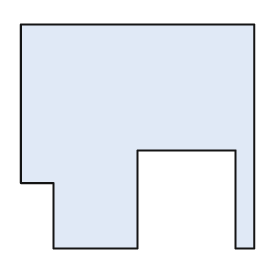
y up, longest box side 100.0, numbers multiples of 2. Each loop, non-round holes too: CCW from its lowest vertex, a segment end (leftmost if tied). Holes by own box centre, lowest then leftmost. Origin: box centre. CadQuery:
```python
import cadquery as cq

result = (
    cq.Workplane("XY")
    .moveTo(-36.0, -48.0)
    .lineTo(0.0, -48.0)
    .lineTo(0.0, -6.0)
    .lineTo(42.0, -6.0)
    .lineTo(42.0, -48.0)
    .lineTo(50.0, -48.0)
    .lineTo(50.0, 48.0)
    .lineTo(-50.0, 48.0)
    .lineTo(-50.0, -20.0)
    .lineTo(-36.0, -20.0)
    .close()
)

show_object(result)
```